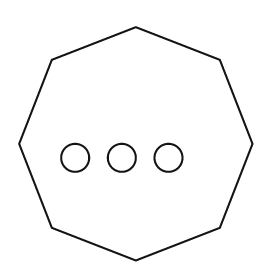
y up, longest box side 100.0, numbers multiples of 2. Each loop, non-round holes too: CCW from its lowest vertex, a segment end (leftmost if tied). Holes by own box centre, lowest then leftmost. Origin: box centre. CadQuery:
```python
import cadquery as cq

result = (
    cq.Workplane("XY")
    .moveTo(0.0, -50.0)
    .lineTo(36.0, -36.0)
    .lineTo(50.0, 0.0)
    .lineTo(36.0, 36.0)
    .lineTo(0.0, 50.0)
    .lineTo(-36.0, 36.0)
    .lineTo(-50.0, 0.0)
    .lineTo(-36.0, -36.0)
    .close()
    .moveTo(-26.0, -6.0)
    .circle(6.0)
    .moveTo(-6.0, -6.0)
    .circle(6.0)
    .moveTo(14.0, -6.0)
    .circle(6.0)
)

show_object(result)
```